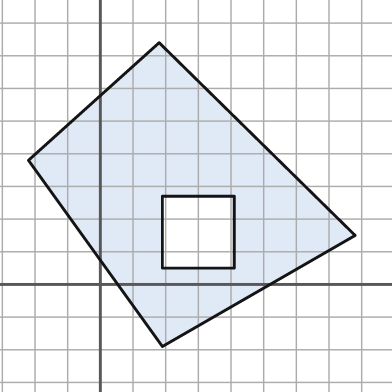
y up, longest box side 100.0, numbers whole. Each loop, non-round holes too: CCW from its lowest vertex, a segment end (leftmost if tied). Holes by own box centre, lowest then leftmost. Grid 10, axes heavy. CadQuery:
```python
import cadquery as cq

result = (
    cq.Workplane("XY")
    .moveTo(19.0, -19.0)
    .lineTo(78.0, 15.0)
    .lineTo(18.0, 74.0)
    .lineTo(-22.0, 38.0)
    .close()
    .moveTo(19.0, 5.0)
    .lineTo(41.0, 5.0)
    .lineTo(41.0, 27.0)
    .lineTo(19.0, 27.0)
    .close()
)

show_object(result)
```